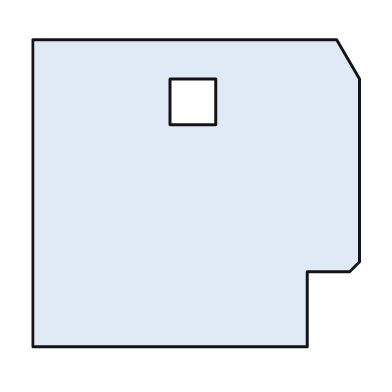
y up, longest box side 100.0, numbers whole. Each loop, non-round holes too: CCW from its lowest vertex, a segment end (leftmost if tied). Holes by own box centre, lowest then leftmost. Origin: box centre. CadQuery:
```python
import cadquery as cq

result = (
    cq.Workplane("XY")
    .moveTo(-50.0, -47.0)
    .lineTo(34.0, -47.0)
    .lineTo(34.0, -24.0)
    .lineTo(47.0, -24.0)
    .lineTo(50.0, -21.0)
    .lineTo(50.0, 35.0)
    .lineTo(43.0, 47.0)
    .lineTo(-50.0, 47.0)
    .close()
    .moveTo(-8.0, 21.0)
    .lineTo(6.0, 21.0)
    .lineTo(6.0, 35.0)
    .lineTo(-8.0, 35.0)
    .close()
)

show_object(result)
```